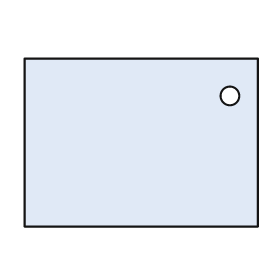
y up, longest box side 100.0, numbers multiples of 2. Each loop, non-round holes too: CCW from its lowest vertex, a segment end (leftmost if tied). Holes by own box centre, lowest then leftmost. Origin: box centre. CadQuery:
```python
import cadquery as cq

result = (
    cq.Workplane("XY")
    .moveTo(-50.0, -36.0)
    .lineTo(50.0, -36.0)
    .lineTo(50.0, 36.0)
    .lineTo(-50.0, 36.0)
    .close()
    .moveTo(38.0, 20.0)
    .circle(4.0)
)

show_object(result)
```